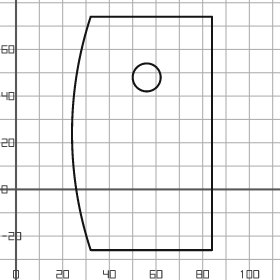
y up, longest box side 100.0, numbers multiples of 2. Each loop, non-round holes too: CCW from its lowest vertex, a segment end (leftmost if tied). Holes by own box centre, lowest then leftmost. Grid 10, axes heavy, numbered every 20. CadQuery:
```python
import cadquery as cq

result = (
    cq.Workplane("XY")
    .moveTo(32.0, -26.0)
    .lineTo(84.0, -26.0)
    .lineTo(84.0, 74.0)
    .lineTo(32.0, 74.0)
    .threePointArc((24.0, 24.0), (32.0, -26.0))
    .close()
    .moveTo(56.0, 48.0)
    .circle(6.0)
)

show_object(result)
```